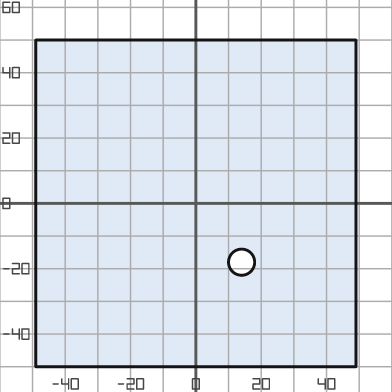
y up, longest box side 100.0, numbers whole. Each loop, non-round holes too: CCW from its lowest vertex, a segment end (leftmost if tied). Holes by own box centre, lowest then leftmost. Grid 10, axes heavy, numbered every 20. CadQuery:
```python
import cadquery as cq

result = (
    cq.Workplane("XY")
    .moveTo(-49.0, -50.0)
    .lineTo(49.0, -50.0)
    .lineTo(49.0, 50.0)
    .lineTo(-49.0, 50.0)
    .close()
    .moveTo(14.0, -18.0)
    .circle(4.0)
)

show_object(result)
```